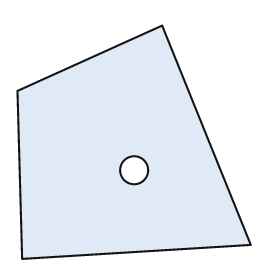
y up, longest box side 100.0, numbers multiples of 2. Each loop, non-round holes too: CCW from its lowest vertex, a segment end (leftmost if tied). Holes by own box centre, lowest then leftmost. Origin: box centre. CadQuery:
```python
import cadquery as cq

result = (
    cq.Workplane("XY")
    .moveTo(-48.0, -50.0)
    .lineTo(50.0, -44.0)
    .lineTo(12.0, 50.0)
    .lineTo(-50.0, 22.0)
    .close()
    .moveTo(0.0, -12.0)
    .circle(6.0)
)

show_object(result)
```